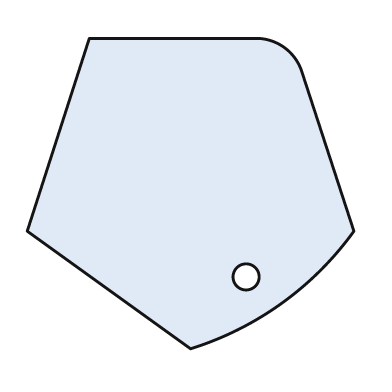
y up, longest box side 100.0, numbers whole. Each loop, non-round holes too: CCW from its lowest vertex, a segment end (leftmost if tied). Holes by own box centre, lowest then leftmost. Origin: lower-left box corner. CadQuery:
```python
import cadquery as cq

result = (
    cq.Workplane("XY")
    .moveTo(50.0, 0.0)
    .threePointArc((78.0, 14.0), (100.0, 36.0))
    .lineTo(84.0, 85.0)
    .threePointArc((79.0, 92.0), (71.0, 95.0))
    .lineTo(19.0, 95.0)
    .lineTo(0.0, 36.0)
    .close()
    .moveTo(67.0, 22.0)
    .circle(4.0)
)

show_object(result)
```